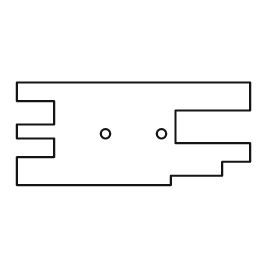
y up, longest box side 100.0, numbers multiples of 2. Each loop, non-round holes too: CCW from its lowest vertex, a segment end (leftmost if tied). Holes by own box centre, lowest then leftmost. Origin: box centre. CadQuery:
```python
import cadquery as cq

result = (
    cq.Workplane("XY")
    .moveTo(-50.0, -22.0)
    .lineTo(16.0, -22.0)
    .lineTo(16.0, -18.0)
    .lineTo(38.0, -18.0)
    .lineTo(38.0, -12.0)
    .lineTo(50.0, -12.0)
    .lineTo(50.0, -4.0)
    .lineTo(18.0, -4.0)
    .lineTo(18.0, 10.0)
    .lineTo(50.0, 10.0)
    .lineTo(50.0, 22.0)
    .lineTo(-50.0, 22.0)
    .lineTo(-50.0, 14.0)
    .lineTo(-34.0, 14.0)
    .lineTo(-34.0, 4.0)
    .lineTo(-50.0, 4.0)
    .lineTo(-50.0, -2.0)
    .lineTo(-34.0, -2.0)
    .lineTo(-34.0, -10.0)
    .lineTo(-50.0, -10.0)
    .close()
    .moveTo(-12.0, 0.0)
    .circle(2.0)
    .moveTo(12.0, 0.0)
    .circle(2.0)
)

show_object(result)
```